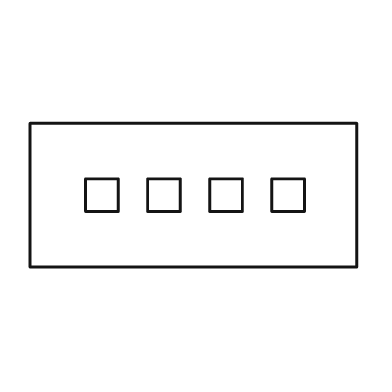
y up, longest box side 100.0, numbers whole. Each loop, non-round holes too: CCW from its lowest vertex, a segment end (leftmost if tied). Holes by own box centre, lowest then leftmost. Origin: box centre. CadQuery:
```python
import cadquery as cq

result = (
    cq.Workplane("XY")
    .moveTo(-50.0, -22.0)
    .lineTo(50.0, -22.0)
    .lineTo(50.0, 22.0)
    .lineTo(-50.0, 22.0)
    .close()
    .moveTo(-33.0, -5.0)
    .lineTo(-23.0, -5.0)
    .lineTo(-23.0, 5.0)
    .lineTo(-33.0, 5.0)
    .close()
    .moveTo(-14.0, -5.0)
    .lineTo(-4.0, -5.0)
    .lineTo(-4.0, 5.0)
    .lineTo(-14.0, 5.0)
    .close()
    .moveTo(5.0, -5.0)
    .lineTo(15.0, -5.0)
    .lineTo(15.0, 5.0)
    .lineTo(5.0, 5.0)
    .close()
    .moveTo(24.0, -5.0)
    .lineTo(34.0, -5.0)
    .lineTo(34.0, 5.0)
    .lineTo(24.0, 5.0)
    .close()
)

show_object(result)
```